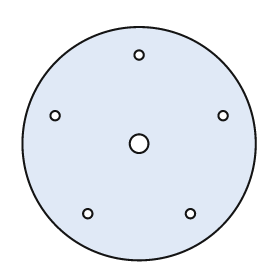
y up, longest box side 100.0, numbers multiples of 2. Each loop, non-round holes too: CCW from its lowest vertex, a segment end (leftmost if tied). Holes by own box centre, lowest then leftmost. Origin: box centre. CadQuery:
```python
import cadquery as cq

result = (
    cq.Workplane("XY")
    .moveTo(0.0, 0.0)
    .circle(50.0)
    .moveTo(-22.0, -30.0)
    .circle(2.0)
    .moveTo(22.0, -30.0)
    .circle(2.0)
    .moveTo(0.0, 0.0)
    .circle(4.0)
    .moveTo(-36.0, 12.0)
    .circle(2.0)
    .moveTo(36.0, 12.0)
    .circle(2.0)
    .moveTo(0.0, 38.0)
    .circle(2.0)
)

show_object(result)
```